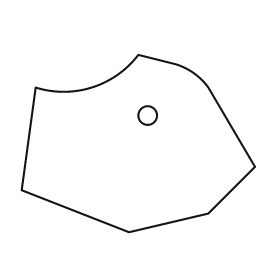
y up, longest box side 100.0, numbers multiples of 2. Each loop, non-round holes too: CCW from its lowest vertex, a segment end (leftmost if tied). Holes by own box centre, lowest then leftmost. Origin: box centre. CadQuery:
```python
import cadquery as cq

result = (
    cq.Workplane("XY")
    .moveTo(-4.0, -38.0)
    .lineTo(30.0, -30.0)
    .lineTo(50.0, -10.0)
    .lineTo(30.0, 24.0)
    .threePointArc((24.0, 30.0), (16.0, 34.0))
    .lineTo(0.0, 38.0)
    .threePointArc((-20.0, 24.0), (-44.0, 24.0))
    .lineTo(-50.0, -20.0)
    .close()
    .moveTo(4.0, 12.0)
    .circle(4.0)
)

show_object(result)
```